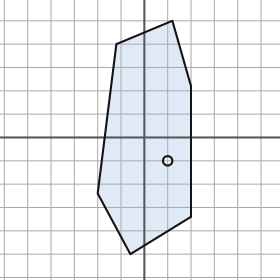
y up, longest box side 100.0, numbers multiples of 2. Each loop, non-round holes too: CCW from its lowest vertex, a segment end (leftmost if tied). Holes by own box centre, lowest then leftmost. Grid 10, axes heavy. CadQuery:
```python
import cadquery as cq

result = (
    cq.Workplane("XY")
    .moveTo(-6.0, -50.0)
    .lineTo(20.0, -34.0)
    .lineTo(20.0, 22.0)
    .lineTo(12.0, 50.0)
    .lineTo(-12.0, 40.0)
    .lineTo(-20.0, -24.0)
    .close()
    .moveTo(10.0, -10.0)
    .circle(2.0)
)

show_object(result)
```